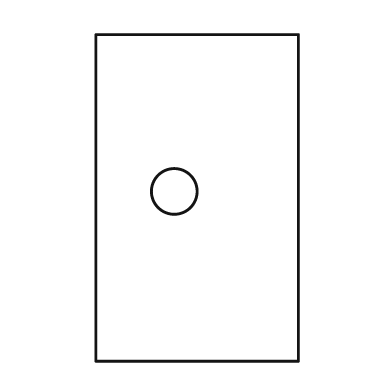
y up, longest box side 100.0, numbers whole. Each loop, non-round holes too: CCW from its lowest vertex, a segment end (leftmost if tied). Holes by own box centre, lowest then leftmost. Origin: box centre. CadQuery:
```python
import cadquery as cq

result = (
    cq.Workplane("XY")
    .moveTo(-31.0, -50.0)
    .lineTo(31.0, -50.0)
    .lineTo(31.0, 50.0)
    .lineTo(-31.0, 50.0)
    .close()
    .moveTo(-7.0, 2.0)
    .circle(7.0)
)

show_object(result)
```